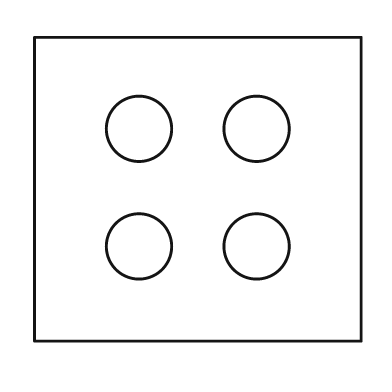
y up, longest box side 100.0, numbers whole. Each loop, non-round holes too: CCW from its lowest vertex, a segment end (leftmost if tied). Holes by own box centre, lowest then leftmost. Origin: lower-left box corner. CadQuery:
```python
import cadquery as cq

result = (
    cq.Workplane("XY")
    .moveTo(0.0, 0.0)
    .lineTo(100.0, 0.0)
    .lineTo(100.0, 93.0)
    .lineTo(0.0, 93.0)
    .close()
    .moveTo(32.0, 29.0)
    .circle(10.0)
    .moveTo(68.0, 29.0)
    .circle(10.0)
    .moveTo(32.0, 65.0)
    .circle(10.0)
    .moveTo(68.0, 65.0)
    .circle(10.0)
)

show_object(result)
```